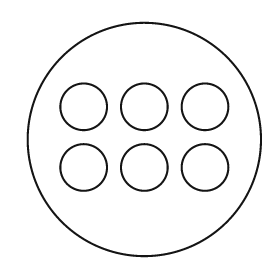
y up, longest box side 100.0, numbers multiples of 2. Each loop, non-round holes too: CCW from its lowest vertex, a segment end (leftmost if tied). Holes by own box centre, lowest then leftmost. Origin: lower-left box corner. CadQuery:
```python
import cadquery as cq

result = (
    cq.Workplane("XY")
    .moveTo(50.0, 50.0)
    .circle(50.0)
    .moveTo(24.0, 38.0)
    .circle(10.0)
    .moveTo(50.0, 38.0)
    .circle(10.0)
    .moveTo(76.0, 38.0)
    .circle(10.0)
    .moveTo(24.0, 64.0)
    .circle(10.0)
    .moveTo(50.0, 64.0)
    .circle(10.0)
    .moveTo(76.0, 64.0)
    .circle(10.0)
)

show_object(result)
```